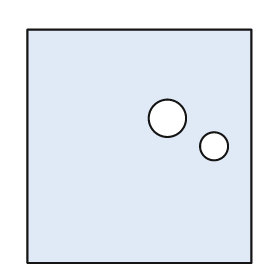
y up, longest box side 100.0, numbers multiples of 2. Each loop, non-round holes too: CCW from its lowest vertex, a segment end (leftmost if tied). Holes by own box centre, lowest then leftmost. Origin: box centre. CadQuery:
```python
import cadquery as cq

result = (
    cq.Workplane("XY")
    .moveTo(-48.0, -50.0)
    .lineTo(48.0, -50.0)
    .lineTo(48.0, 50.0)
    .lineTo(-48.0, 50.0)
    .close()
    .moveTo(32.0, 0.0)
    .circle(6.0)
    .moveTo(12.0, 12.0)
    .circle(8.0)
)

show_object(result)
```